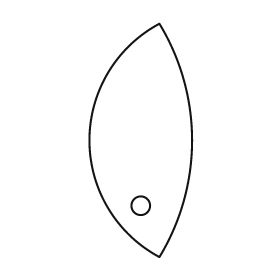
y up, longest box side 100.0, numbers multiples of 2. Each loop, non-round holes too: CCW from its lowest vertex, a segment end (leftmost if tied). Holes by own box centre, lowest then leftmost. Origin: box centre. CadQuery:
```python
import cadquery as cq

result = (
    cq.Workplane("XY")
    .moveTo(8.0, -50.0)
    .threePointArc((22.0, 0.0), (8.0, 50.0))
    .threePointArc((-22.0, 0.0), (8.0, -50.0))
    .close()
    .moveTo(0.0, -28.0)
    .circle(4.0)
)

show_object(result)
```